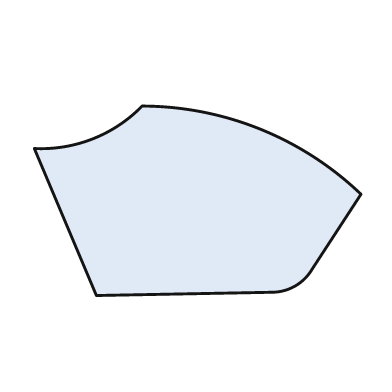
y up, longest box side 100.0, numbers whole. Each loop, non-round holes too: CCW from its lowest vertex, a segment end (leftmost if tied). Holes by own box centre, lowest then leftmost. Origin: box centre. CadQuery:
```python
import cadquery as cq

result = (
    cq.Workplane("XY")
    .moveTo(-31.0, -29.0)
    .lineTo(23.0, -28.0)
    .threePointArc((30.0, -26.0), (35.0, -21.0))
    .lineTo(50.0, 2.0)
    .threePointArc((19.0, 22.0), (-17.0, 29.0))
    .threePointArc((-32.0, 19.0), (-50.0, 16.0))
    .close()
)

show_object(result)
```